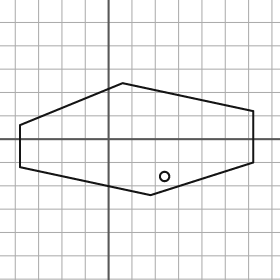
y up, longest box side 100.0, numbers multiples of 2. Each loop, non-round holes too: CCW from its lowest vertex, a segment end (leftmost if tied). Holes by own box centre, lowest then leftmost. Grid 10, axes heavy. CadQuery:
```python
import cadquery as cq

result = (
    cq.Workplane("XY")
    .moveTo(18.0, -24.0)
    .lineTo(62.0, -10.0)
    .lineTo(62.0, 12.0)
    .lineTo(6.0, 24.0)
    .lineTo(-38.0, 6.0)
    .lineTo(-38.0, -12.0)
    .close()
    .moveTo(24.0, -16.0)
    .circle(2.0)
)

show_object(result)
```